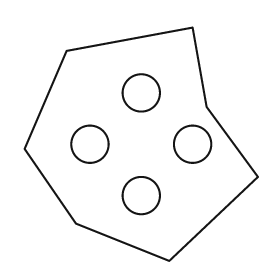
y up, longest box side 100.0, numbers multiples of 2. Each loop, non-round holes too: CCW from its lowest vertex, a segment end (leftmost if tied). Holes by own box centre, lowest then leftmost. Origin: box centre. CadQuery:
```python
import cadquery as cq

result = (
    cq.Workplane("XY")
    .moveTo(12.0, -50.0)
    .lineTo(50.0, -14.0)
    .lineTo(28.0, 16.0)
    .lineTo(22.0, 50.0)
    .lineTo(-32.0, 40.0)
    .lineTo(-50.0, -2.0)
    .lineTo(-28.0, -34.0)
    .close()
    .moveTo(0.0, -22.0)
    .circle(8.0)
    .moveTo(-22.0, 0.0)
    .circle(8.0)
    .moveTo(22.0, 0.0)
    .circle(8.0)
    .moveTo(0.0, 22.0)
    .circle(8.0)
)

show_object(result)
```